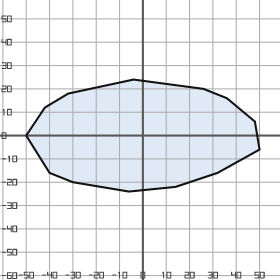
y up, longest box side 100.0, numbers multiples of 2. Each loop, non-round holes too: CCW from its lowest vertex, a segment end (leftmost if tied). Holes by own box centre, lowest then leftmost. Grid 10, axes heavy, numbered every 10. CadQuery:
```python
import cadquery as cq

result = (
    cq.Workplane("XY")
    .moveTo(-6.0, -24.0)
    .lineTo(14.0, -22.0)
    .lineTo(32.0, -16.0)
    .lineTo(50.0, -6.0)
    .lineTo(48.0, 6.0)
    .lineTo(36.0, 16.0)
    .lineTo(26.0, 20.0)
    .lineTo(-4.0, 24.0)
    .lineTo(-32.0, 18.0)
    .lineTo(-42.0, 12.0)
    .lineTo(-50.0, 0.0)
    .lineTo(-40.0, -16.0)
    .lineTo(-30.0, -20.0)
    .close()
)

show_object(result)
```